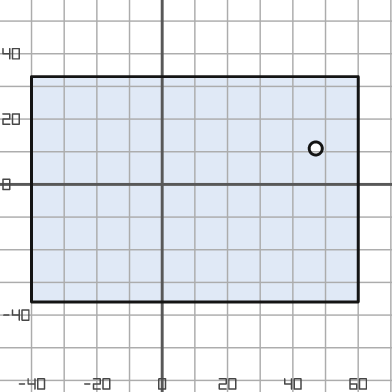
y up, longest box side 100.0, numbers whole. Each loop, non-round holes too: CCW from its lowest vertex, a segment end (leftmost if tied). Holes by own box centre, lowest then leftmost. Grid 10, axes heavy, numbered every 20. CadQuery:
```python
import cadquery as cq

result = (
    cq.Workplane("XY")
    .moveTo(-40.0, -36.0)
    .lineTo(60.0, -36.0)
    .lineTo(60.0, 33.0)
    .lineTo(-40.0, 33.0)
    .close()
    .moveTo(47.0, 11.0)
    .circle(2.0)
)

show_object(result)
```